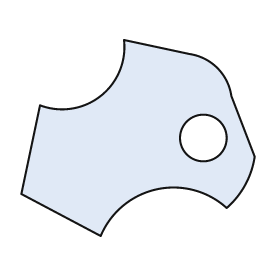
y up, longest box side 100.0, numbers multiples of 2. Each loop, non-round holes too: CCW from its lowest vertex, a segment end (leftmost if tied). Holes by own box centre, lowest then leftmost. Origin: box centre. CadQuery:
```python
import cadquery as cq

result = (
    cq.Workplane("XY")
    .moveTo(-16.0, -42.0)
    .threePointArc((8.0, -22.0), (38.0, -30.0))
    .threePointArc((46.0, -20.0), (50.0, -8.0))
    .lineTo(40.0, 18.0)
    .threePointArc((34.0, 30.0), (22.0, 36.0))
    .lineTo(-6.0, 42.0)
    .threePointArc((-16.0, 18.0), (-42.0, 14.0))
    .lineTo(-50.0, -24.0)
    .close()
    .moveTo(28.0, 0.0)
    .circle(10.0)
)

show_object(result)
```